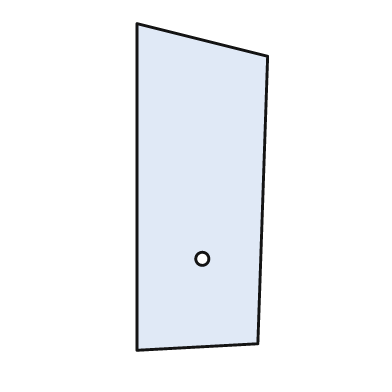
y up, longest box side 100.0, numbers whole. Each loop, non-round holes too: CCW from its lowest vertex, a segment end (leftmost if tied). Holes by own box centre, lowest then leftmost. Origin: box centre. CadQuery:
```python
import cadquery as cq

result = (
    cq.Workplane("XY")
    .moveTo(-20.0, -50.0)
    .lineTo(17.0, -48.0)
    .lineTo(20.0, 40.0)
    .lineTo(-20.0, 50.0)
    .close()
    .moveTo(0.0, -22.0)
    .circle(2.0)
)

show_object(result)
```